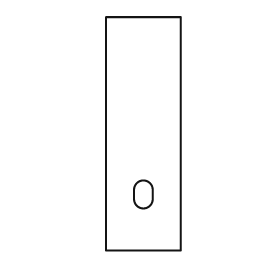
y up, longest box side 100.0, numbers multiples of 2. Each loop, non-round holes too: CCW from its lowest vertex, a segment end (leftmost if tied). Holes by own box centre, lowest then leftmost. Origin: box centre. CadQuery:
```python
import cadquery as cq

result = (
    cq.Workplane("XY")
    .moveTo(-16.0, -50.0)
    .lineTo(16.0, -50.0)
    .lineTo(16.0, 50.0)
    .lineTo(-16.0, 50.0)
    .close()
    .moveTo(-4.0, -28.0)
    .threePointArc((0.0, -32.0), (4.0, -28.0))
    .lineTo(4.0, -24.0)
    .threePointArc((0.0, -20.0), (-4.0, -24.0))
    .close()
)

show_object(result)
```